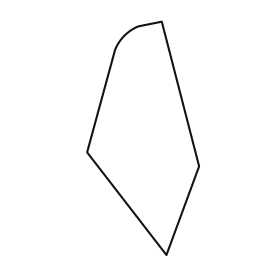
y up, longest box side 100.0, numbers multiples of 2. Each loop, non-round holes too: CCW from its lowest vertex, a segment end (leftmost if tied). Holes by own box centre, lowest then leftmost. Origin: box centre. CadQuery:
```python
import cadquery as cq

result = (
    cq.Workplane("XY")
    .moveTo(10.0, -50.0)
    .lineTo(24.0, -12.0)
    .lineTo(8.0, 50.0)
    .lineTo(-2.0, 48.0)
    .threePointArc((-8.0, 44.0), (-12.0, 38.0))
    .lineTo(-24.0, -6.0)
    .close()
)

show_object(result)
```